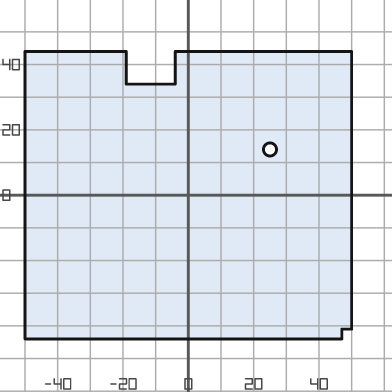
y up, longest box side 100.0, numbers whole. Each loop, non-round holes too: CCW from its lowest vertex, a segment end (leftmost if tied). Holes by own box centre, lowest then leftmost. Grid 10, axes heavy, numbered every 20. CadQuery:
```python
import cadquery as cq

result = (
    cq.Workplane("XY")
    .moveTo(-50.0, -44.0)
    .lineTo(47.0, -44.0)
    .lineTo(47.0, -41.0)
    .lineTo(50.0, -41.0)
    .lineTo(50.0, 44.0)
    .lineTo(-4.0, 44.0)
    .lineTo(-4.0, 34.0)
    .lineTo(-19.0, 34.0)
    .lineTo(-19.0, 44.0)
    .lineTo(-50.0, 44.0)
    .close()
    .moveTo(25.0, 14.0)
    .circle(2.0)
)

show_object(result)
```